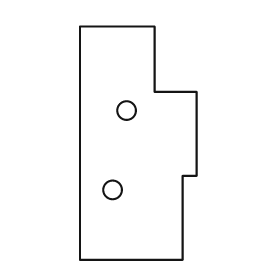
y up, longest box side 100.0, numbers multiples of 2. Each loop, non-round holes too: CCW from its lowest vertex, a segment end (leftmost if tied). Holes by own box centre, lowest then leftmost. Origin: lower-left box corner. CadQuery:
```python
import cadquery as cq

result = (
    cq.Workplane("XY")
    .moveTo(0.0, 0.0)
    .lineTo(44.0, 0.0)
    .lineTo(44.0, 36.0)
    .lineTo(50.0, 36.0)
    .lineTo(50.0, 72.0)
    .lineTo(32.0, 72.0)
    .lineTo(32.0, 100.0)
    .lineTo(0.0, 100.0)
    .close()
    .moveTo(14.0, 30.0)
    .circle(4.0)
    .moveTo(20.0, 64.0)
    .circle(4.0)
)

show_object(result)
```